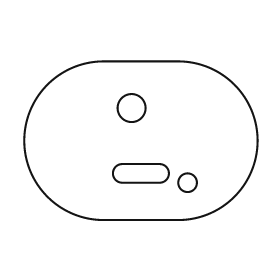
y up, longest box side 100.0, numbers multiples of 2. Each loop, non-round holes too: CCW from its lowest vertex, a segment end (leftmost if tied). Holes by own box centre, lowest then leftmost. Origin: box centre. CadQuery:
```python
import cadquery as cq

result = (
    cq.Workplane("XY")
    .moveTo(-16.0, -34.0)
    .lineTo(16.0, -34.0)
    .threePointArc((50.0, 0.0), (16.0, 34.0))
    .lineTo(-16.0, 34.0)
    .threePointArc((-50.0, 0.0), (-16.0, -34.0))
    .close()
    .moveTo(20.0, -18.0)
    .circle(4.0)
    .moveTo(-8.0, -18.0)
    .lineTo(8.0, -18.0)
    .threePointArc((12.0, -14.0), (8.0, -10.0))
    .lineTo(-8.0, -10.0)
    .threePointArc((-12.0, -14.0), (-8.0, -18.0))
    .close()
    .moveTo(-4.0, 14.0)
    .circle(6.0)
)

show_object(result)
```